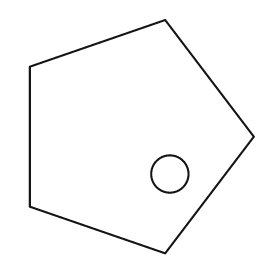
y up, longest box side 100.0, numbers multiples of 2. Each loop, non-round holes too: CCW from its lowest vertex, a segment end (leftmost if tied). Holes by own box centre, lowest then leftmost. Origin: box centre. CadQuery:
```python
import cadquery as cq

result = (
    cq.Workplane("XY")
    .moveTo(10.0, -50.0)
    .lineTo(48.0, 0.0)
    .lineTo(10.0, 50.0)
    .lineTo(-48.0, 30.0)
    .lineTo(-48.0, -30.0)
    .close()
    .moveTo(12.0, -16.0)
    .circle(8.0)
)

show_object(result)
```